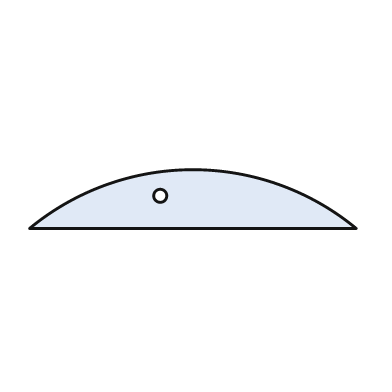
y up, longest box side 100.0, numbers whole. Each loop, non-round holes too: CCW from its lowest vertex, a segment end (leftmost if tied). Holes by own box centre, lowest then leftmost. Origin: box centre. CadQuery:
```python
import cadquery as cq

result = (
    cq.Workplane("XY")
    .moveTo(-50.0, -9.0)
    .lineTo(50.0, -9.0)
    .threePointArc((0.0, 9.0), (-50.0, -9.0))
    .close()
    .moveTo(-10.0, 1.0)
    .circle(2.0)
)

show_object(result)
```